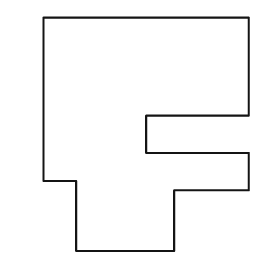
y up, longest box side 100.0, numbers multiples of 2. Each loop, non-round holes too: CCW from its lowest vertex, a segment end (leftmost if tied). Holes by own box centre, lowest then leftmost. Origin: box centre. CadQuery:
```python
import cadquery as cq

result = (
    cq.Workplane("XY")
    .moveTo(-30.0, -50.0)
    .lineTo(12.0, -50.0)
    .lineTo(12.0, -24.0)
    .lineTo(44.0, -24.0)
    .lineTo(44.0, -8.0)
    .lineTo(0.0, -8.0)
    .lineTo(0.0, 8.0)
    .lineTo(44.0, 8.0)
    .lineTo(44.0, 50.0)
    .lineTo(-44.0, 50.0)
    .lineTo(-44.0, -20.0)
    .lineTo(-30.0, -20.0)
    .close()
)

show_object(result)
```